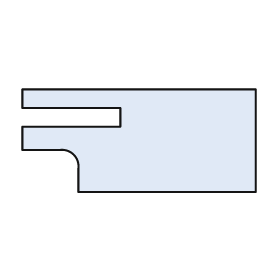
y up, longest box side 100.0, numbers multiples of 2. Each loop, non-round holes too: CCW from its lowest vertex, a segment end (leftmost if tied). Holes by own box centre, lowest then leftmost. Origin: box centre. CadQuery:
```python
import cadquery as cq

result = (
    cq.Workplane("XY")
    .moveTo(-26.0, -22.0)
    .lineTo(50.0, -22.0)
    .lineTo(50.0, 22.0)
    .lineTo(-50.0, 22.0)
    .lineTo(-50.0, 14.0)
    .lineTo(-8.0, 14.0)
    .lineTo(-8.0, 6.0)
    .lineTo(-50.0, 6.0)
    .lineTo(-50.0, -4.0)
    .lineTo(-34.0, -4.0)
    .threePointArc((-28.0, -6.0), (-26.0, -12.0))
    .close()
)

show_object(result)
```